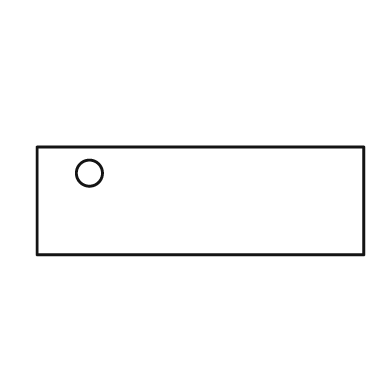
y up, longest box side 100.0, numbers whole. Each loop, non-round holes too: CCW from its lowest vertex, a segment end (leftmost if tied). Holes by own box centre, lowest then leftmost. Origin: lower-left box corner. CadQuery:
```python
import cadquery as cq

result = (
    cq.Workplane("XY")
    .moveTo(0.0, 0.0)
    .lineTo(100.0, 0.0)
    .lineTo(100.0, 33.0)
    .lineTo(0.0, 33.0)
    .close()
    .moveTo(16.0, 25.0)
    .circle(4.0)
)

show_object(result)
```